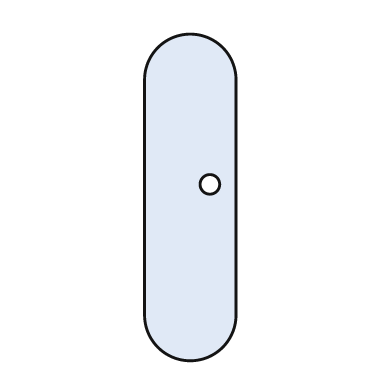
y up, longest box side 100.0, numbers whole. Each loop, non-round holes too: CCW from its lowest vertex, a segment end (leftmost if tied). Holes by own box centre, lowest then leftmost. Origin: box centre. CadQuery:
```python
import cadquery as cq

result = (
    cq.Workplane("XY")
    .moveTo(-14.0, -36.0)
    .threePointArc((0.0, -50.0), (14.0, -36.0))
    .lineTo(14.0, 36.0)
    .threePointArc((0.0, 50.0), (-14.0, 36.0))
    .close()
    .moveTo(6.0, 4.0)
    .circle(3.0)
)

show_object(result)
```